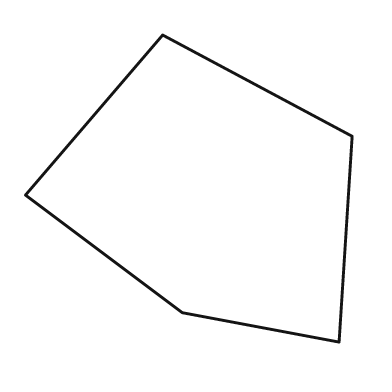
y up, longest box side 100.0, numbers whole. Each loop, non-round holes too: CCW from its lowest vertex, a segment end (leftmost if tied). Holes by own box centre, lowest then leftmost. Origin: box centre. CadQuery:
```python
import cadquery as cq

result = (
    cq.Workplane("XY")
    .moveTo(46.0, -47.0)
    .lineTo(50.0, 16.0)
    .lineTo(-8.0, 47.0)
    .lineTo(-50.0, -2.0)
    .lineTo(-2.0, -38.0)
    .close()
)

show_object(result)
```